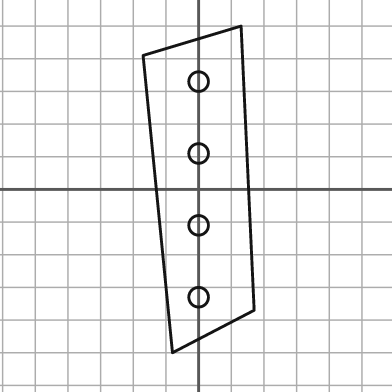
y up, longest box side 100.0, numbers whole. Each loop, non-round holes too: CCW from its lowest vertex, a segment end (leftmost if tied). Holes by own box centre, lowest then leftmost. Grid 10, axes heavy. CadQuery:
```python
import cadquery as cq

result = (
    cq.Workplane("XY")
    .moveTo(-8.0, -50.0)
    .lineTo(17.0, -37.0)
    .lineTo(13.0, 50.0)
    .lineTo(-17.0, 41.0)
    .close()
    .moveTo(0.0, -33.0)
    .circle(3.0)
    .moveTo(0.0, -11.0)
    .circle(3.0)
    .moveTo(0.0, 11.0)
    .circle(3.0)
    .moveTo(0.0, 33.0)
    .circle(3.0)
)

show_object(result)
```